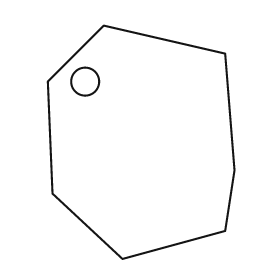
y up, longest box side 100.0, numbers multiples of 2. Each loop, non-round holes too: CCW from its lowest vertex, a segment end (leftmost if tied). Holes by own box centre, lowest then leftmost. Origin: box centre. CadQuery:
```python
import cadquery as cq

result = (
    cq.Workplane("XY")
    .moveTo(-8.0, -50.0)
    .lineTo(36.0, -38.0)
    .lineTo(40.0, -12.0)
    .lineTo(36.0, 38.0)
    .lineTo(-16.0, 50.0)
    .lineTo(-40.0, 26.0)
    .lineTo(-38.0, -22.0)
    .close()
    .moveTo(-24.0, 26.0)
    .circle(6.0)
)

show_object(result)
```